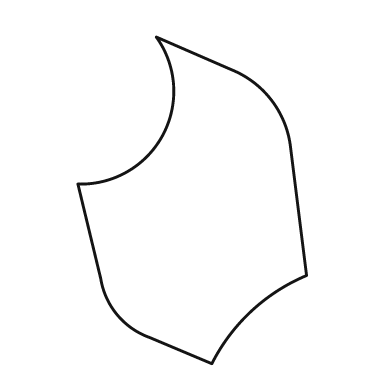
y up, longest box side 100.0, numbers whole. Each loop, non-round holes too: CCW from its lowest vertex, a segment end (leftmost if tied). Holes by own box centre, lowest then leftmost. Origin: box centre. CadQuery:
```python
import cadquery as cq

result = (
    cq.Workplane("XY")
    .moveTo(6.0, -50.0)
    .threePointArc((18.0, -34.0), (35.0, -23.0))
    .lineTo(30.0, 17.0)
    .threePointArc((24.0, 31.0), (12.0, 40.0))
    .lineTo(-11.0, 50.0)
    .threePointArc((-9.0, 20.0), (-35.0, 5.0))
    .lineTo(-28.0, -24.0)
    .threePointArc((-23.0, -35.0), (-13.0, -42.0))
    .close()
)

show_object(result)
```